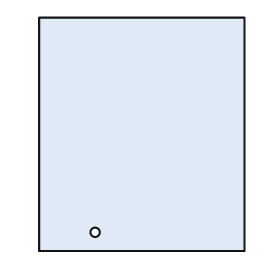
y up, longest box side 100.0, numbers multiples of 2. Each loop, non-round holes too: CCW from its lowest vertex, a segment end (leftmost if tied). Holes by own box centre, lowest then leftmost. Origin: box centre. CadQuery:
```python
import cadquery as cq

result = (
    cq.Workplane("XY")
    .moveTo(-44.0, -50.0)
    .lineTo(44.0, -50.0)
    .lineTo(44.0, 50.0)
    .lineTo(-44.0, 50.0)
    .close()
    .moveTo(-20.0, -42.0)
    .circle(2.0)
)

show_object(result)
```